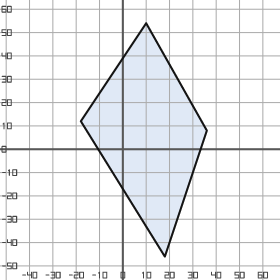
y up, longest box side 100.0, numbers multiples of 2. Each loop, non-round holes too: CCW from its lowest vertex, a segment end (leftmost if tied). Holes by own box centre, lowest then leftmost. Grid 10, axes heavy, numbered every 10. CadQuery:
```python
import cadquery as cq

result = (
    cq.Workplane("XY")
    .moveTo(18.0, -46.0)
    .lineTo(36.0, 8.0)
    .lineTo(10.0, 54.0)
    .lineTo(-18.0, 12.0)
    .close()
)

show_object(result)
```